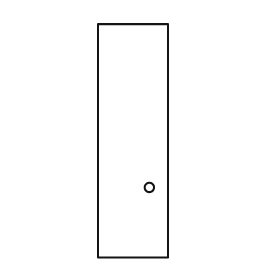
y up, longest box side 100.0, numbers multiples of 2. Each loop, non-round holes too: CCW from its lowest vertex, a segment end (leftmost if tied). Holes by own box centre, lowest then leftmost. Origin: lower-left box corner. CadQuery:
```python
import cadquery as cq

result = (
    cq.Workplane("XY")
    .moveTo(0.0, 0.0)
    .lineTo(30.0, 0.0)
    .lineTo(30.0, 100.0)
    .lineTo(0.0, 100.0)
    .close()
    .moveTo(22.0, 30.0)
    .circle(2.0)
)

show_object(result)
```